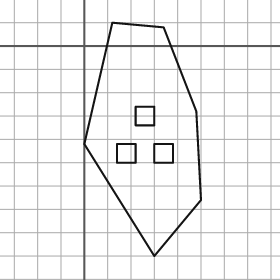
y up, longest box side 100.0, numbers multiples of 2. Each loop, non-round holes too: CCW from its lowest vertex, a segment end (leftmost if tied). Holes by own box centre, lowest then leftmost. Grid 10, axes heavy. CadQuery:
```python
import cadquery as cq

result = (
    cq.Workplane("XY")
    .moveTo(30.0, -90.0)
    .lineTo(50.0, -66.0)
    .lineTo(48.0, -28.0)
    .lineTo(34.0, 8.0)
    .lineTo(12.0, 10.0)
    .lineTo(0.0, -42.0)
    .close()
    .moveTo(14.0, -50.0)
    .lineTo(22.0, -50.0)
    .lineTo(22.0, -42.0)
    .lineTo(14.0, -42.0)
    .close()
    .moveTo(30.0, -50.0)
    .lineTo(38.0, -50.0)
    .lineTo(38.0, -42.0)
    .lineTo(30.0, -42.0)
    .close()
    .moveTo(22.0, -34.0)
    .lineTo(30.0, -34.0)
    .lineTo(30.0, -26.0)
    .lineTo(22.0, -26.0)
    .close()
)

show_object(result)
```